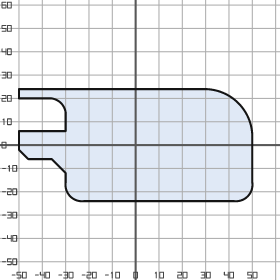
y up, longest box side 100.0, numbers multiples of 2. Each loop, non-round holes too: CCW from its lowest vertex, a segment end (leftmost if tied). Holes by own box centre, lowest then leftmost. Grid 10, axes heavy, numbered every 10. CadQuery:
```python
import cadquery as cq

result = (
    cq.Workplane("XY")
    .moveTo(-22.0, -24.0)
    .lineTo(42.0, -24.0)
    .threePointArc((48.0, -22.0), (50.0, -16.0))
    .lineTo(50.0, 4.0)
    .threePointArc((44.0, 18.0), (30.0, 24.0))
    .lineTo(-50.0, 24.0)
    .lineTo(-50.0, 20.0)
    .lineTo(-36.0, 20.0)
    .threePointArc((-32.0, 18.0), (-30.0, 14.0))
    .lineTo(-30.0, 6.0)
    .lineTo(-50.0, 6.0)
    .lineTo(-50.0, -2.0)
    .lineTo(-46.0, -6.0)
    .lineTo(-36.0, -6.0)
    .lineTo(-30.0, -12.0)
    .lineTo(-30.0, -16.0)
    .threePointArc((-28.0, -22.0), (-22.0, -24.0))
    .close()
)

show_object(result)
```